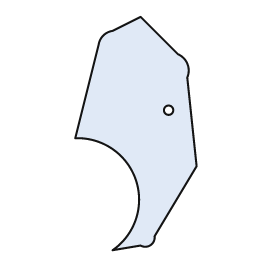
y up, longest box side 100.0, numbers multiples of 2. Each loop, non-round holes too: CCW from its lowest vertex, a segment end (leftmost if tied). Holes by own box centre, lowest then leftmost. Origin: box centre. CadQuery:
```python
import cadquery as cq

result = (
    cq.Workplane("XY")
    .moveTo(-10.0, -50.0)
    .lineTo(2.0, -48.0)
    .threePointArc((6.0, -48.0), (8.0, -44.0))
    .lineTo(26.0, -14.0)
    .lineTo(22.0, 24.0)
    .threePointArc((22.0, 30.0), (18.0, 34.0))
    .lineTo(2.0, 50.0)
    .lineTo(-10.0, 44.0)
    .threePointArc((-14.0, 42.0), (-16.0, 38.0))
    .lineTo(-26.0, -2.0)
    .threePointArc((0.0, -20.0), (-10.0, -50.0))
    .close()
    .moveTo(14.0, 10.0)
    .circle(2.0)
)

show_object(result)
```